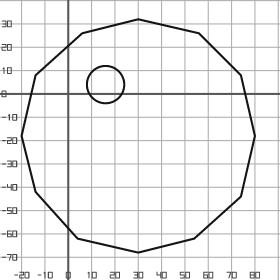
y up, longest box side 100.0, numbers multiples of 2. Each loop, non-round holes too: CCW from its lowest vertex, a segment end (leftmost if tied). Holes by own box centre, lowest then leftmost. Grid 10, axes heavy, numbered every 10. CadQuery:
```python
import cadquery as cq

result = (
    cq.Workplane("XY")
    .moveTo(30.0, -68.0)
    .lineTo(54.0, -62.0)
    .lineTo(74.0, -44.0)
    .lineTo(80.0, -18.0)
    .lineTo(74.0, 8.0)
    .lineTo(56.0, 26.0)
    .lineTo(30.0, 32.0)
    .lineTo(6.0, 26.0)
    .lineTo(-14.0, 8.0)
    .lineTo(-20.0, -18.0)
    .lineTo(-14.0, -42.0)
    .lineTo(4.0, -62.0)
    .close()
    .moveTo(16.0, 4.0)
    .circle(8.0)
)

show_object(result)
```